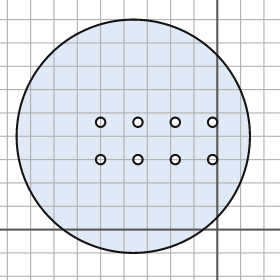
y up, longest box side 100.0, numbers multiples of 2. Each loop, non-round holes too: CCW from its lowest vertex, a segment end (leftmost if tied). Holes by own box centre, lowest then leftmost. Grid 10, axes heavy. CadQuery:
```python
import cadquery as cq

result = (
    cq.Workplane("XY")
    .moveTo(-36.0, 40.0)
    .circle(50.0)
    .moveTo(-50.0, 30.0)
    .circle(2.0)
    .moveTo(-34.0, 30.0)
    .circle(2.0)
    .moveTo(-18.0, 30.0)
    .circle(2.0)
    .moveTo(-2.0, 30.0)
    .circle(2.0)
    .moveTo(-50.0, 46.0)
    .circle(2.0)
    .moveTo(-34.0, 46.0)
    .circle(2.0)
    .moveTo(-18.0, 46.0)
    .circle(2.0)
    .moveTo(-2.0, 46.0)
    .circle(2.0)
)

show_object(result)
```